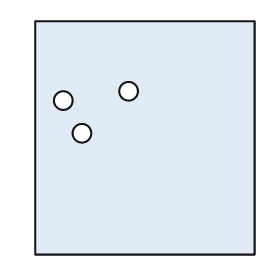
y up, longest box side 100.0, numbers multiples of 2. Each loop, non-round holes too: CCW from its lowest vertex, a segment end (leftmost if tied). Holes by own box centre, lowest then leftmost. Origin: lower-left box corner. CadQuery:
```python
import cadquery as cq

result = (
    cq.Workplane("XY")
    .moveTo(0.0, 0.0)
    .lineTo(94.0, 0.0)
    .lineTo(94.0, 100.0)
    .lineTo(0.0, 100.0)
    .close()
    .moveTo(20.0, 52.0)
    .circle(4.0)
    .moveTo(12.0, 66.0)
    .circle(4.0)
    .moveTo(40.0, 70.0)
    .circle(4.0)
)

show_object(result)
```